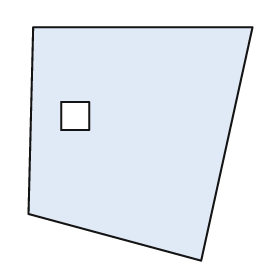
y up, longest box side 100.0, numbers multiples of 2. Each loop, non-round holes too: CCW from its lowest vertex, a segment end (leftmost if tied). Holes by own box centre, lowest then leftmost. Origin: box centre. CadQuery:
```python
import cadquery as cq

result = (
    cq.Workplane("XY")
    .moveTo(26.0, -50.0)
    .lineTo(48.0, 50.0)
    .lineTo(-46.0, 50.0)
    .lineTo(-48.0, -30.0)
    .close()
    .moveTo(-34.0, 6.0)
    .lineTo(-22.0, 6.0)
    .lineTo(-22.0, 18.0)
    .lineTo(-34.0, 18.0)
    .close()
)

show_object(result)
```